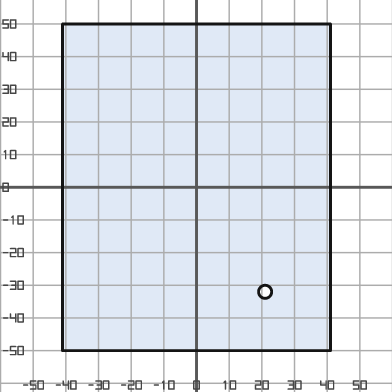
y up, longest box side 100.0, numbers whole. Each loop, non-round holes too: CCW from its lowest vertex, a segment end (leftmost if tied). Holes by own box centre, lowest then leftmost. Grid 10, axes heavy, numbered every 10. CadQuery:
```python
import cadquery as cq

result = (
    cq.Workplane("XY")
    .moveTo(-41.0, -50.0)
    .lineTo(41.0, -50.0)
    .lineTo(41.0, 50.0)
    .lineTo(-41.0, 50.0)
    .close()
    .moveTo(21.0, -32.0)
    .circle(2.0)
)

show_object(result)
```